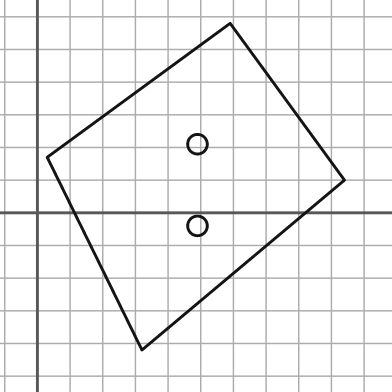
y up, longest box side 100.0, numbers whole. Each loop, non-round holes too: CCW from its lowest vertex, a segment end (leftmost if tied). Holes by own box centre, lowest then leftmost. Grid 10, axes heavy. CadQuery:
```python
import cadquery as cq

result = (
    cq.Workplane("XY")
    .moveTo(32.0, -42.0)
    .lineTo(94.0, 10.0)
    .lineTo(59.0, 58.0)
    .lineTo(3.0, 17.0)
    .close()
    .moveTo(49.0, -4.0)
    .circle(3.0)
    .moveTo(49.0, 21.0)
    .circle(3.0)
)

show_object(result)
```